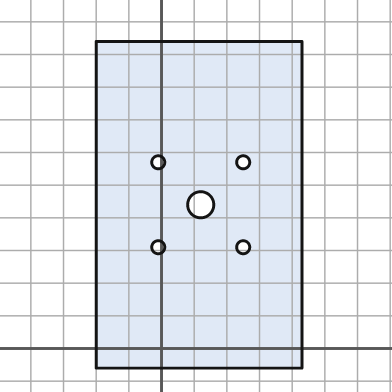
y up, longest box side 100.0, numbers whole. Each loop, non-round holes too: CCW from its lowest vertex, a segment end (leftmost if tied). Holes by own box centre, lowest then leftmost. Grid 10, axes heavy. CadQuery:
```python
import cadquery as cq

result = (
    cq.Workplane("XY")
    .moveTo(-20.0, -6.0)
    .lineTo(43.0, -6.0)
    .lineTo(43.0, 94.0)
    .lineTo(-20.0, 94.0)
    .close()
    .moveTo(-1.0, 31.0)
    .circle(2.0)
    .moveTo(25.0, 31.0)
    .circle(2.0)
    .moveTo(12.0, 44.0)
    .circle(4.0)
    .moveTo(-1.0, 57.0)
    .circle(2.0)
    .moveTo(25.0, 57.0)
    .circle(2.0)
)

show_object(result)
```